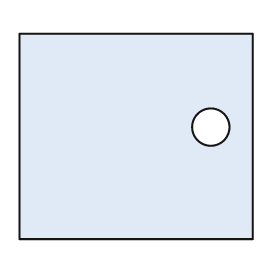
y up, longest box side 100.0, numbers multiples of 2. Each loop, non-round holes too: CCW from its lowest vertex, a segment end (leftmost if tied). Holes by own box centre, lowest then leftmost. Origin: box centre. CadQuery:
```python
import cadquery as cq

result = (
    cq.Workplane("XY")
    .moveTo(-50.0, -44.0)
    .lineTo(50.0, -44.0)
    .lineTo(50.0, 44.0)
    .lineTo(-50.0, 44.0)
    .close()
    .moveTo(32.0, 4.0)
    .circle(8.0)
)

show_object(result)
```